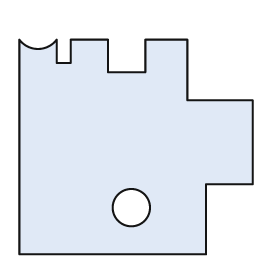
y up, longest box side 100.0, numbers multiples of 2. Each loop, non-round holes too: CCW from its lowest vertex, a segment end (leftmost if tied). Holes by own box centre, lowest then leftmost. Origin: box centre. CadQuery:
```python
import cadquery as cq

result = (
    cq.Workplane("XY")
    .moveTo(-50.0, -46.0)
    .lineTo(30.0, -46.0)
    .lineTo(30.0, -16.0)
    .lineTo(50.0, -16.0)
    .lineTo(50.0, 20.0)
    .lineTo(22.0, 20.0)
    .lineTo(22.0, 46.0)
    .lineTo(4.0, 46.0)
    .lineTo(4.0, 32.0)
    .lineTo(-12.0, 32.0)
    .lineTo(-12.0, 46.0)
    .lineTo(-28.0, 46.0)
    .lineTo(-28.0, 36.0)
    .lineTo(-34.0, 36.0)
    .lineTo(-34.0, 46.0)
    .threePointArc((-42.0, 42.0), (-50.0, 46.0))
    .close()
    .moveTo(-2.0, -26.0)
    .circle(8.0)
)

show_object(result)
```